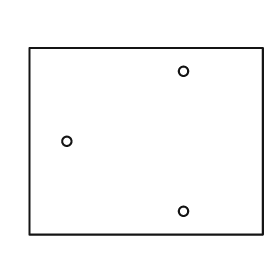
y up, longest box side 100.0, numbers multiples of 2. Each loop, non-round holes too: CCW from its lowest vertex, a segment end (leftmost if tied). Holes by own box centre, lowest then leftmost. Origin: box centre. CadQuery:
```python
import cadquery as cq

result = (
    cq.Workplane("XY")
    .moveTo(-50.0, -40.0)
    .lineTo(50.0, -40.0)
    .lineTo(50.0, 40.0)
    .lineTo(-50.0, 40.0)
    .close()
    .moveTo(16.0, -30.0)
    .circle(2.0)
    .moveTo(-34.0, 0.0)
    .circle(2.0)
    .moveTo(16.0, 30.0)
    .circle(2.0)
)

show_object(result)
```